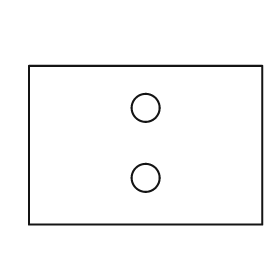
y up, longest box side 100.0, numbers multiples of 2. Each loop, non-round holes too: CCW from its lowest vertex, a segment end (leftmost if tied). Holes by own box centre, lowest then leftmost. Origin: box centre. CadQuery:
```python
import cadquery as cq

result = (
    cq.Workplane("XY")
    .moveTo(-50.0, -34.0)
    .lineTo(50.0, -34.0)
    .lineTo(50.0, 34.0)
    .lineTo(-50.0, 34.0)
    .close()
    .moveTo(0.0, -14.0)
    .circle(6.0)
    .moveTo(0.0, 16.0)
    .circle(6.0)
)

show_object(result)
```